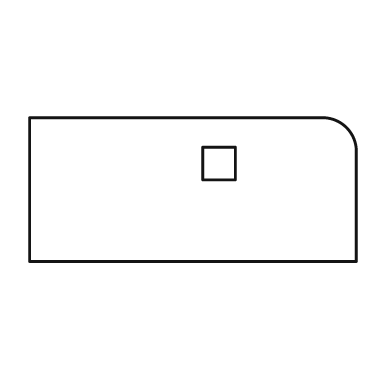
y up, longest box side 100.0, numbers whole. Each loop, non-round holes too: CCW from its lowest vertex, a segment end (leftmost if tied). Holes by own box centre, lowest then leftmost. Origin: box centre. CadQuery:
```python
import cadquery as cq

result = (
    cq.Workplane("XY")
    .moveTo(-50.0, -22.0)
    .lineTo(50.0, -22.0)
    .lineTo(50.0, 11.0)
    .threePointArc((47.0, 19.0), (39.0, 22.0))
    .lineTo(-50.0, 22.0)
    .close()
    .moveTo(3.0, 3.0)
    .lineTo(13.0, 3.0)
    .lineTo(13.0, 13.0)
    .lineTo(3.0, 13.0)
    .close()
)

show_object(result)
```